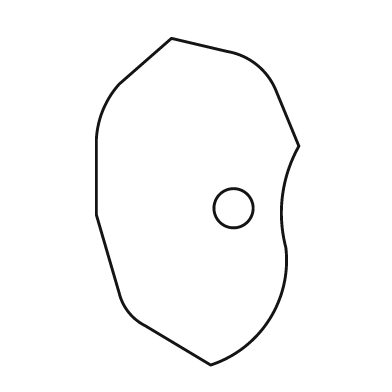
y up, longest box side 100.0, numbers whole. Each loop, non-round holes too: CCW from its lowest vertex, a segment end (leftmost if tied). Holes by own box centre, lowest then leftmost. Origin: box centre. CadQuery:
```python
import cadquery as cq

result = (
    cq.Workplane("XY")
    .moveTo(4.0, -50.0)
    .threePointArc((22.0, -36.0), (27.0, -14.0))
    .threePointArc((26.0, 2.0), (31.0, 17.0))
    .lineTo(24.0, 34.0)
    .threePointArc((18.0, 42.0), (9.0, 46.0))
    .lineTo(-8.0, 50.0)
    .lineTo(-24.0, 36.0)
    .threePointArc((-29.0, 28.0), (-31.0, 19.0))
    .lineTo(-31.0, -4.0)
    .lineTo(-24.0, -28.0)
    .threePointArc((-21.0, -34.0), (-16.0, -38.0))
    .close()
    .moveTo(11.0, -2.0)
    .circle(6.0)
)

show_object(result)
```